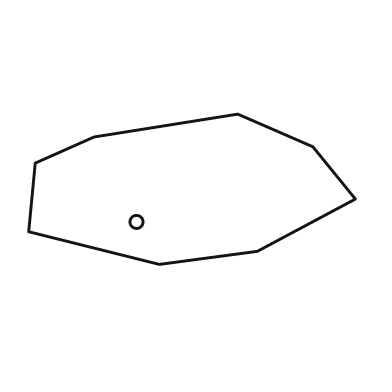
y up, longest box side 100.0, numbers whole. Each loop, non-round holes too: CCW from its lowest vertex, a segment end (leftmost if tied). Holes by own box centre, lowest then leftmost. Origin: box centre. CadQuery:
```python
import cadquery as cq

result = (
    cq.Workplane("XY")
    .moveTo(-10.0, -23.0)
    .lineTo(20.0, -19.0)
    .lineTo(50.0, -3.0)
    .lineTo(37.0, 13.0)
    .lineTo(14.0, 23.0)
    .lineTo(-30.0, 16.0)
    .lineTo(-48.0, 8.0)
    .lineTo(-50.0, -13.0)
    .close()
    .moveTo(-17.0, -10.0)
    .circle(2.0)
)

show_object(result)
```